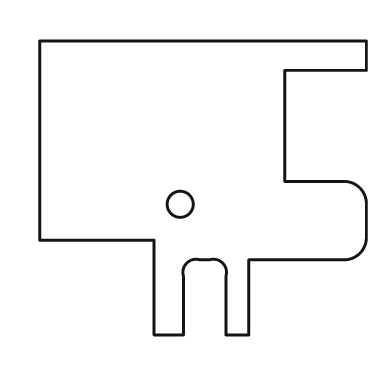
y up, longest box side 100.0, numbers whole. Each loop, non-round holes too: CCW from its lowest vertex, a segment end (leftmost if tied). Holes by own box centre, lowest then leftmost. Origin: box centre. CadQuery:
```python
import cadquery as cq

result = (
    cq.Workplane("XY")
    .moveTo(-15.0, -45.0)
    .lineTo(-6.0, -45.0)
    .lineTo(-6.0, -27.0)
    .threePointArc((-5.0, -23.0), (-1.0, -22.0))
    .lineTo(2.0, -22.0)
    .threePointArc((6.0, -23.0), (7.0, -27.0))
    .lineTo(7.0, -45.0)
    .lineTo(14.0, -45.0)
    .lineTo(14.0, -22.0)
    .lineTo(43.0, -22.0)
    .threePointArc((48.0, -20.0), (50.0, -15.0))
    .lineTo(50.0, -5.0)
    .threePointArc((48.0, 0.0), (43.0, 2.0))
    .lineTo(25.0, 2.0)
    .lineTo(25.0, 36.0)
    .lineTo(50.0, 36.0)
    .lineTo(50.0, 45.0)
    .lineTo(-50.0, 45.0)
    .lineTo(-50.0, -16.0)
    .lineTo(-15.0, -16.0)
    .close()
    .moveTo(-7.0, -5.0)
    .circle(4.0)
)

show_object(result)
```